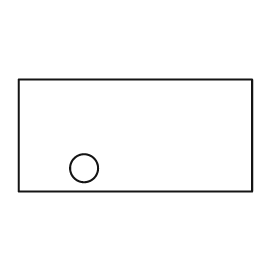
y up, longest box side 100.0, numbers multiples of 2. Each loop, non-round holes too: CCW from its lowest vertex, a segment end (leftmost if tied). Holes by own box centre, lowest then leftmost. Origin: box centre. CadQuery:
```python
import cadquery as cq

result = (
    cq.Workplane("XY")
    .moveTo(-50.0, -24.0)
    .lineTo(50.0, -24.0)
    .lineTo(50.0, 24.0)
    .lineTo(-50.0, 24.0)
    .close()
    .moveTo(-22.0, -14.0)
    .circle(6.0)
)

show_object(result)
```